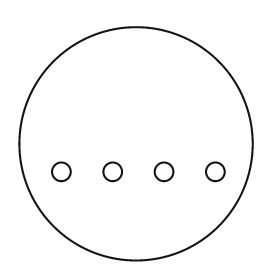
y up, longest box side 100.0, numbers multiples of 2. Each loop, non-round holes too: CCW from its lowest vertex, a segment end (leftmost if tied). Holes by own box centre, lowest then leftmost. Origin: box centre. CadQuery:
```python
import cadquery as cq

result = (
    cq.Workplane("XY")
    .moveTo(0.0, 0.0)
    .circle(50.0)
    .moveTo(-32.0, -12.0)
    .circle(4.0)
    .moveTo(-10.0, -12.0)
    .circle(4.0)
    .moveTo(12.0, -12.0)
    .circle(4.0)
    .moveTo(34.0, -12.0)
    .circle(4.0)
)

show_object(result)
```